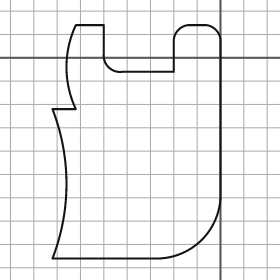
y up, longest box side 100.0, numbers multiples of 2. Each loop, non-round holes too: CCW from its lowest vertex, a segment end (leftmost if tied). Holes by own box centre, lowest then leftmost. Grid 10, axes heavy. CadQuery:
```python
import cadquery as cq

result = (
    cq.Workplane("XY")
    .moveTo(-72.0, -86.0)
    .lineTo(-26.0, -86.0)
    .threePointArc((-8.0, -78.0), (0.0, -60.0))
    .lineTo(0.0, 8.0)
    .threePointArc((-2.0, 12.0), (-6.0, 14.0))
    .lineTo(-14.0, 14.0)
    .threePointArc((-18.0, 12.0), (-20.0, 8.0))
    .lineTo(-20.0, -6.0)
    .lineTo(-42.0, -6.0)
    .threePointArc((-48.0, -4.0), (-50.0, 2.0))
    .lineTo(-50.0, 14.0)
    .lineTo(-62.0, 14.0)
    .threePointArc((-66.0, -4.0), (-62.0, -22.0))
    .lineTo(-72.0, -22.0)
    .threePointArc((-66.0, -54.0), (-72.0, -86.0))
    .close()
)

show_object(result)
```